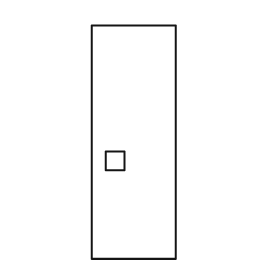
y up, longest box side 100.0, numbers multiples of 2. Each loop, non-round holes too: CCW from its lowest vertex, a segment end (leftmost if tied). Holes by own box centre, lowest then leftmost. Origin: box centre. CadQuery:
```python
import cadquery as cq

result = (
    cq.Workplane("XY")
    .moveTo(-18.0, -50.0)
    .lineTo(18.0, -50.0)
    .lineTo(18.0, 50.0)
    .lineTo(-18.0, 50.0)
    .close()
    .moveTo(-12.0, -12.0)
    .lineTo(-4.0, -12.0)
    .lineTo(-4.0, -4.0)
    .lineTo(-12.0, -4.0)
    .close()
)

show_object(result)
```